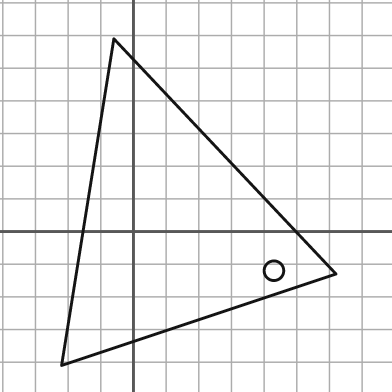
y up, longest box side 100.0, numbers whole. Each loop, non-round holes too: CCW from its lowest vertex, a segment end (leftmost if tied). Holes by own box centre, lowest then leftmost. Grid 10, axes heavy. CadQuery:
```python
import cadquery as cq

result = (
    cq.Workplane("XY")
    .moveTo(-22.0, -41.0)
    .lineTo(62.0, -13.0)
    .lineTo(-6.0, 59.0)
    .close()
    .moveTo(43.0, -12.0)
    .circle(3.0)
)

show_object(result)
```